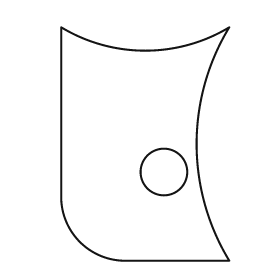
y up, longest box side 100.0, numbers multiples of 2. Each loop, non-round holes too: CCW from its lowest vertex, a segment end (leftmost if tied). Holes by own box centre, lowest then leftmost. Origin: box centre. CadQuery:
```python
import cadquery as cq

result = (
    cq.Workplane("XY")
    .moveTo(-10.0, -50.0)
    .lineTo(36.0, -50.0)
    .threePointArc((22.0, 0.0), (36.0, 50.0))
    .threePointArc((0.0, 40.0), (-36.0, 50.0))
    .lineTo(-36.0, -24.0)
    .threePointArc((-28.0, -42.0), (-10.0, -50.0))
    .close()
    .moveTo(8.0, -12.0)
    .circle(10.0)
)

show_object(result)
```